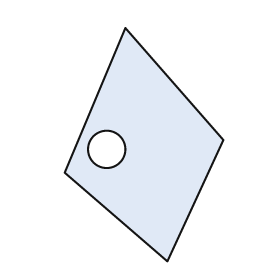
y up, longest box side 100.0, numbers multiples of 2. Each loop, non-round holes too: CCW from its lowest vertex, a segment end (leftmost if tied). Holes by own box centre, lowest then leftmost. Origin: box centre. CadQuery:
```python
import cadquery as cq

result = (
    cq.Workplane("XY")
    .moveTo(10.0, -50.0)
    .lineTo(34.0, 2.0)
    .lineTo(-8.0, 50.0)
    .lineTo(-34.0, -12.0)
    .close()
    .moveTo(-16.0, -2.0)
    .circle(8.0)
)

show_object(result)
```